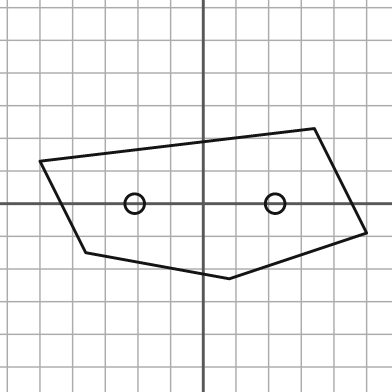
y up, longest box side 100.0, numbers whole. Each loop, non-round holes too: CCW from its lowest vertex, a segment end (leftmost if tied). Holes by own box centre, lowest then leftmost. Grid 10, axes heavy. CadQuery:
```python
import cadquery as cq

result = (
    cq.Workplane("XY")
    .moveTo(8.0, -23.0)
    .lineTo(50.0, -9.0)
    .lineTo(34.0, 23.0)
    .lineTo(-50.0, 13.0)
    .lineTo(-36.0, -15.0)
    .close()
    .moveTo(-21.0, 0.0)
    .circle(3.0)
    .moveTo(22.0, 0.0)
    .circle(3.0)
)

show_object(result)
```